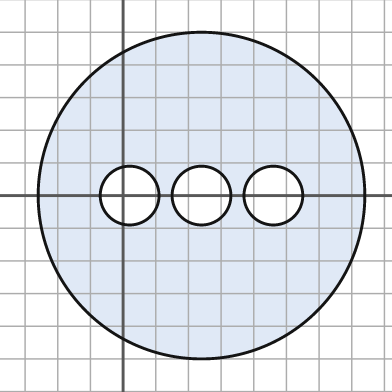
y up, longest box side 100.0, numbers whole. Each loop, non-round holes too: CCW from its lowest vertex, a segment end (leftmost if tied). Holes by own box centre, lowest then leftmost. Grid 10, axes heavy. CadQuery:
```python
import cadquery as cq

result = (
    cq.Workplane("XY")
    .moveTo(24.0, 0.0)
    .circle(50.0)
    .moveTo(2.0, 0.0)
    .circle(9.0)
    .moveTo(24.0, 0.0)
    .circle(9.0)
    .moveTo(46.0, 0.0)
    .circle(9.0)
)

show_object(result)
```